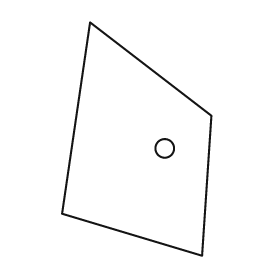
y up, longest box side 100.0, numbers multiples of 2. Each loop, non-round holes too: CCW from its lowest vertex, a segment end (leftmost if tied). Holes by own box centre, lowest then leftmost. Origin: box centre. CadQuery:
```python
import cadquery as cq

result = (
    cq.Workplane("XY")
    .moveTo(28.0, -50.0)
    .lineTo(32.0, 10.0)
    .lineTo(-20.0, 50.0)
    .lineTo(-32.0, -32.0)
    .close()
    .moveTo(12.0, -4.0)
    .circle(4.0)
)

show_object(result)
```